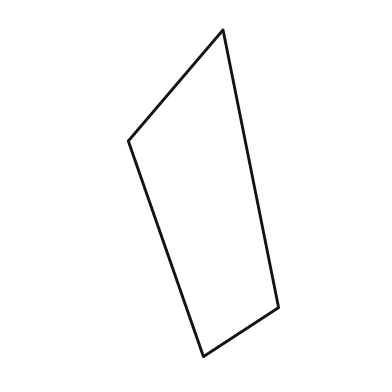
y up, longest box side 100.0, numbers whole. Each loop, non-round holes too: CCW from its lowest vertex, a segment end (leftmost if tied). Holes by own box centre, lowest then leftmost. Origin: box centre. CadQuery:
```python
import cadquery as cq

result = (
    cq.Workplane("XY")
    .moveTo(0.0, -50.0)
    .lineTo(23.0, -35.0)
    .lineTo(6.0, 50.0)
    .lineTo(-23.0, 16.0)
    .close()
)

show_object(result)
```